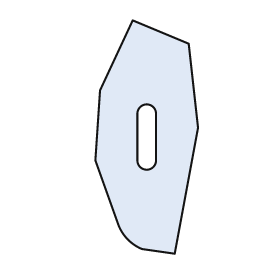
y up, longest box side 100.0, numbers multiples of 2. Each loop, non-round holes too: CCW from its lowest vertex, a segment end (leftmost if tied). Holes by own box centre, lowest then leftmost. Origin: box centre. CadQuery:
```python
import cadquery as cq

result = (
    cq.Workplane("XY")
    .moveTo(12.0, -50.0)
    .lineTo(22.0, 4.0)
    .lineTo(18.0, 40.0)
    .lineTo(-6.0, 50.0)
    .lineTo(-20.0, 20.0)
    .lineTo(-22.0, -10.0)
    .lineTo(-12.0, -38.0)
    .threePointArc((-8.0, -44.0), (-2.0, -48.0))
    .close()
    .moveTo(-4.0, -10.0)
    .threePointArc((0.0, -14.0), (4.0, -10.0))
    .lineTo(4.0, 10.0)
    .threePointArc((0.0, 14.0), (-4.0, 10.0))
    .close()
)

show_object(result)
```